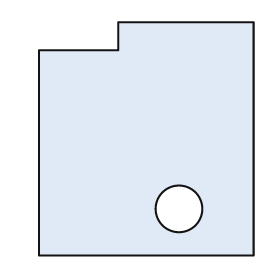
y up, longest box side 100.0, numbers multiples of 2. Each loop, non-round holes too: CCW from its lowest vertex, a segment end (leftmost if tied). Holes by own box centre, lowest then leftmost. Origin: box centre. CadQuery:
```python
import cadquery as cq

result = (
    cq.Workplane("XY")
    .moveTo(-46.0, -50.0)
    .lineTo(46.0, -50.0)
    .lineTo(46.0, 50.0)
    .lineTo(-12.0, 50.0)
    .lineTo(-12.0, 38.0)
    .lineTo(-46.0, 38.0)
    .close()
    .moveTo(14.0, -30.0)
    .circle(10.0)
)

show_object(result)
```